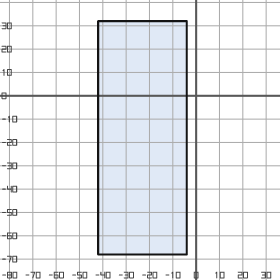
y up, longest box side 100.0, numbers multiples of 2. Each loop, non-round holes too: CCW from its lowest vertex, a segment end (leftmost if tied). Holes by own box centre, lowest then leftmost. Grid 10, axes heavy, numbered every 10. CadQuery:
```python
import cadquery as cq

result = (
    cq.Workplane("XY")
    .moveTo(-42.0, -68.0)
    .lineTo(-4.0, -68.0)
    .lineTo(-4.0, 32.0)
    .lineTo(-42.0, 32.0)
    .close()
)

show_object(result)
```